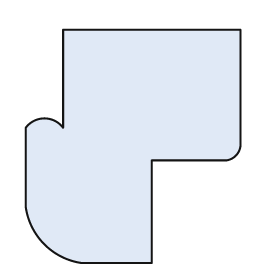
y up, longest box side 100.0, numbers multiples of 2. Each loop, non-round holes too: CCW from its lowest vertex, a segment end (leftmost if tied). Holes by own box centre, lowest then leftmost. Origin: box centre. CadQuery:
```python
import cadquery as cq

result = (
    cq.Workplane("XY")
    .moveTo(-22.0, -50.0)
    .lineTo(8.0, -50.0)
    .lineTo(8.0, -6.0)
    .lineTo(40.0, -6.0)
    .threePointArc((44.0, -4.0), (46.0, 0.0))
    .lineTo(46.0, 50.0)
    .lineTo(-30.0, 50.0)
    .lineTo(-30.0, 8.0)
    .threePointArc((-38.0, 12.0), (-46.0, 8.0))
    .lineTo(-46.0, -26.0)
    .threePointArc((-38.0, -42.0), (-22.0, -50.0))
    .close()
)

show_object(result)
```